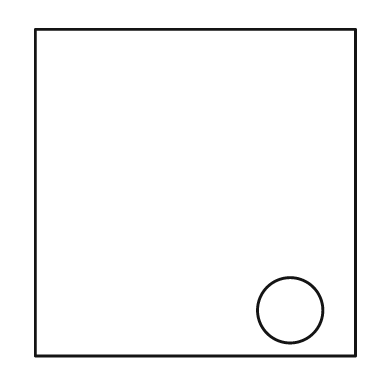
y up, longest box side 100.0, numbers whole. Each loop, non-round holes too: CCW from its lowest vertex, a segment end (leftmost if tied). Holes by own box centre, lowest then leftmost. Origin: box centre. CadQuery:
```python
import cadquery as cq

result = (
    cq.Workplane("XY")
    .moveTo(-49.0, -50.0)
    .lineTo(49.0, -50.0)
    .lineTo(49.0, 50.0)
    .lineTo(-49.0, 50.0)
    .close()
    .moveTo(29.0, -36.0)
    .circle(10.0)
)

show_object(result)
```